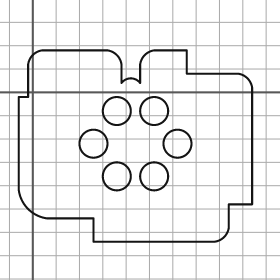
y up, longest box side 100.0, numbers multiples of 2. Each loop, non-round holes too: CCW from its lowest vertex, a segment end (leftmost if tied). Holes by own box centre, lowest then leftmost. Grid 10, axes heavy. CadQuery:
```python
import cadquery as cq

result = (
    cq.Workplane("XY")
    .moveTo(26.0, -64.0)
    .lineTo(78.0, -64.0)
    .threePointArc((82.0, -62.0), (84.0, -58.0))
    .lineTo(84.0, -48.0)
    .lineTo(94.0, -48.0)
    .lineTo(94.0, 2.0)
    .threePointArc((92.0, 6.0), (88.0, 8.0))
    .lineTo(66.0, 8.0)
    .lineTo(66.0, 18.0)
    .lineTo(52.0, 18.0)
    .threePointArc((48.0, 16.0), (46.0, 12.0))
    .lineTo(46.0, 4.0)
    .threePointArc((42.0, 6.0), (38.0, 4.0))
    .lineTo(38.0, 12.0)
    .threePointArc((36.0, 16.0), (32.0, 18.0))
    .lineTo(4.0, 18.0)
    .threePointArc((0.0, 16.0), (-2.0, 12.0))
    .lineTo(-2.0, -2.0)
    .lineTo(-6.0, -2.0)
    .lineTo(-6.0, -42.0)
    .threePointArc((-2.0, -50.0), (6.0, -54.0))
    .lineTo(26.0, -54.0)
    .close()
    .moveTo(36.0, -36.0)
    .circle(6.0)
    .moveTo(52.0, -36.0)
    .circle(6.0)
    .moveTo(26.0, -22.0)
    .circle(6.0)
    .moveTo(62.0, -22.0)
    .circle(6.0)
    .moveTo(36.0, -8.0)
    .circle(6.0)
    .moveTo(52.0, -8.0)
    .circle(6.0)
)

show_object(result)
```